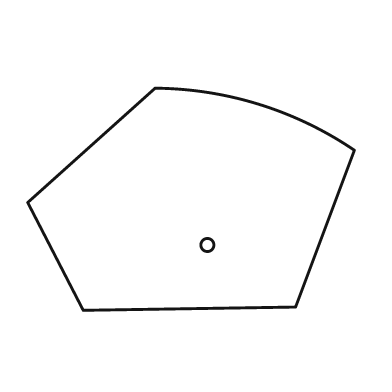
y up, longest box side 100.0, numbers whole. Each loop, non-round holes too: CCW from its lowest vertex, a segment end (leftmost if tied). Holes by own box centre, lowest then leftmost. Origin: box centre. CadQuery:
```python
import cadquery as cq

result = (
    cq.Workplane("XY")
    .moveTo(-33.0, -34.0)
    .lineTo(32.0, -33.0)
    .lineTo(50.0, 15.0)
    .threePointArc((21.0, 29.0), (-11.0, 34.0))
    .lineTo(-50.0, -1.0)
    .close()
    .moveTo(5.0, -14.0)
    .circle(2.0)
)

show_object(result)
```